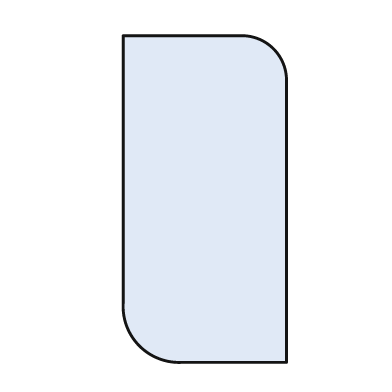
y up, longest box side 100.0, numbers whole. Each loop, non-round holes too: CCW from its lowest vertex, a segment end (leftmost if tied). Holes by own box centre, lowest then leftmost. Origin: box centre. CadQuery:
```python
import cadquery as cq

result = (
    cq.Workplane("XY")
    .moveTo(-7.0, -50.0)
    .lineTo(25.0, -50.0)
    .lineTo(25.0, 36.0)
    .threePointArc((21.0, 46.0), (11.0, 50.0))
    .lineTo(-25.0, 50.0)
    .lineTo(-25.0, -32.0)
    .threePointArc((-20.0, -45.0), (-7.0, -50.0))
    .close()
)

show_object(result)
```